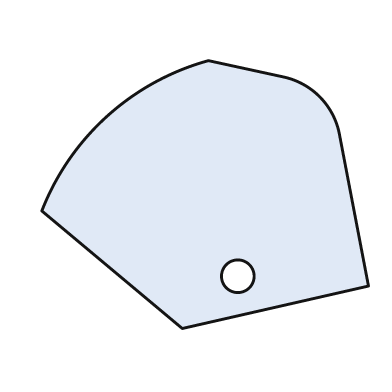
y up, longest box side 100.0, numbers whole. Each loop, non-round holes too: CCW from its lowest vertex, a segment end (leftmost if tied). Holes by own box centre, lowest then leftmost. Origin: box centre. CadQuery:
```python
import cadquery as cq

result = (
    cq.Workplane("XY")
    .moveTo(-7.0, -41.0)
    .lineTo(50.0, -28.0)
    .lineTo(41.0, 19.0)
    .threePointArc((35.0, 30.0), (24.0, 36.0))
    .lineTo(1.0, 41.0)
    .threePointArc((-30.0, 24.0), (-50.0, -5.0))
    .close()
    .moveTo(10.0, -25.0)
    .circle(5.0)
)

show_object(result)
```